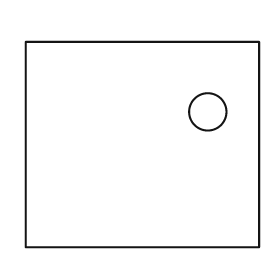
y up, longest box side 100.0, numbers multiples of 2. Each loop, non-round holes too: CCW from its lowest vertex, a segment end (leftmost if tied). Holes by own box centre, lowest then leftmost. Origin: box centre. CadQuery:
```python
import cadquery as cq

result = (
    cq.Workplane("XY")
    .moveTo(-50.0, -44.0)
    .lineTo(50.0, -44.0)
    .lineTo(50.0, 44.0)
    .lineTo(-50.0, 44.0)
    .close()
    .moveTo(28.0, 14.0)
    .circle(8.0)
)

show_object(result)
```